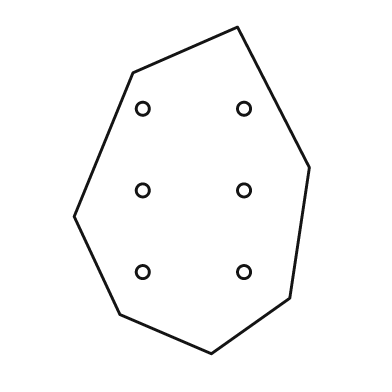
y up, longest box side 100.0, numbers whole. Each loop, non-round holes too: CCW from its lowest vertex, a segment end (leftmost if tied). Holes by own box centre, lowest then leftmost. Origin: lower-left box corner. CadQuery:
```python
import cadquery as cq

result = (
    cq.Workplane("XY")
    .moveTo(42.0, 0.0)
    .lineTo(66.0, 17.0)
    .lineTo(72.0, 57.0)
    .lineTo(50.0, 100.0)
    .lineTo(18.0, 86.0)
    .lineTo(0.0, 42.0)
    .lineTo(14.0, 12.0)
    .close()
    .moveTo(21.0, 25.0)
    .circle(2.0)
    .moveTo(52.0, 25.0)
    .circle(2.0)
    .moveTo(21.0, 50.0)
    .circle(2.0)
    .moveTo(52.0, 50.0)
    .circle(2.0)
    .moveTo(21.0, 75.0)
    .circle(2.0)
    .moveTo(52.0, 75.0)
    .circle(2.0)
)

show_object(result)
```